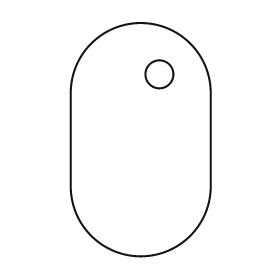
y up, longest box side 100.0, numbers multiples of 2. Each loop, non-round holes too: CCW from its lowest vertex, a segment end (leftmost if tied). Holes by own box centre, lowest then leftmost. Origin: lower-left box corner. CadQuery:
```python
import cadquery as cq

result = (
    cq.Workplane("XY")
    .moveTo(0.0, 30.0)
    .threePointArc((30.0, 0.0), (60.0, 30.0))
    .lineTo(60.0, 70.0)
    .threePointArc((30.0, 100.0), (0.0, 70.0))
    .close()
    .moveTo(38.0, 78.0)
    .circle(6.0)
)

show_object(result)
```